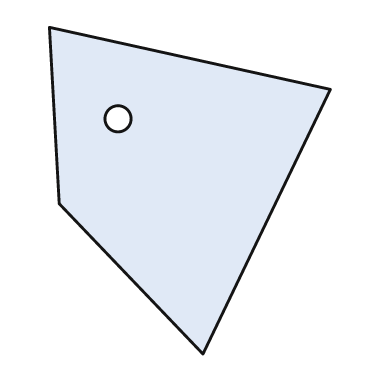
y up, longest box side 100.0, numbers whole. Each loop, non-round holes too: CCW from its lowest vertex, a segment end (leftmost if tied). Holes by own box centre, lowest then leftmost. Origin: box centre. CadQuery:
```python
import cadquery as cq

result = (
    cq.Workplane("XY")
    .moveTo(4.0, -50.0)
    .lineTo(43.0, 31.0)
    .lineTo(-43.0, 50.0)
    .lineTo(-40.0, -4.0)
    .close()
    .moveTo(-22.0, 22.0)
    .circle(4.0)
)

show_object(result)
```